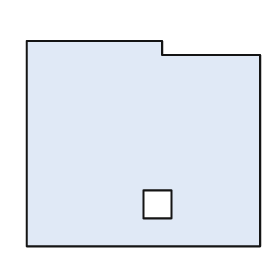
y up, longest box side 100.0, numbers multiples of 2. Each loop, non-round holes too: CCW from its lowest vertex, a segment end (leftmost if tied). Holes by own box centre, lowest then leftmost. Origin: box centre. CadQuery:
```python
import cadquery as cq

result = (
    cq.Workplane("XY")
    .moveTo(-50.0, -44.0)
    .lineTo(50.0, -44.0)
    .lineTo(50.0, 38.0)
    .lineTo(8.0, 38.0)
    .lineTo(8.0, 44.0)
    .lineTo(-50.0, 44.0)
    .close()
    .moveTo(0.0, -32.0)
    .lineTo(12.0, -32.0)
    .lineTo(12.0, -20.0)
    .lineTo(0.0, -20.0)
    .close()
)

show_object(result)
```